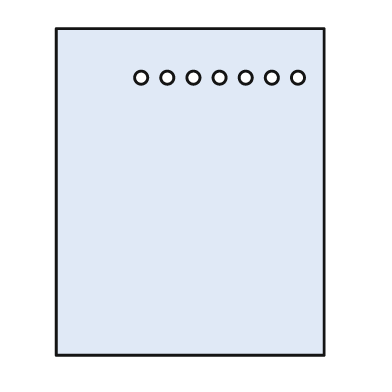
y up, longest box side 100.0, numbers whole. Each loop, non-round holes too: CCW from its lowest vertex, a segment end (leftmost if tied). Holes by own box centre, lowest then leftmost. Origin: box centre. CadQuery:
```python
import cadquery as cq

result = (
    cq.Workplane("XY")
    .moveTo(-41.0, -50.0)
    .lineTo(41.0, -50.0)
    .lineTo(41.0, 50.0)
    .lineTo(-41.0, 50.0)
    .close()
    .moveTo(-15.0, 35.0)
    .circle(2.0)
    .moveTo(-7.0, 35.0)
    .circle(2.0)
    .moveTo(1.0, 35.0)
    .circle(2.0)
    .moveTo(9.0, 35.0)
    .circle(2.0)
    .moveTo(17.0, 35.0)
    .circle(2.0)
    .moveTo(25.0, 35.0)
    .circle(2.0)
    .moveTo(33.0, 35.0)
    .circle(2.0)
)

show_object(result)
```